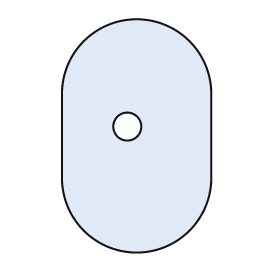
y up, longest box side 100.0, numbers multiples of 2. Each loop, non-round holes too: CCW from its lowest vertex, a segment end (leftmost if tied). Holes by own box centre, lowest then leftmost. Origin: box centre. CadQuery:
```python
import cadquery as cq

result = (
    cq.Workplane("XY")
    .moveTo(-32.0, -18.0)
    .threePointArc((0.0, -50.0), (32.0, -18.0))
    .lineTo(32.0, 18.0)
    .threePointArc((0.0, 50.0), (-32.0, 18.0))
    .close()
    .moveTo(-4.0, 4.0)
    .circle(6.0)
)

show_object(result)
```